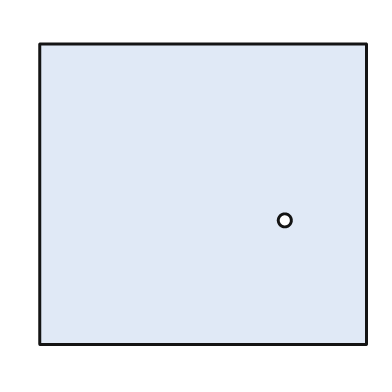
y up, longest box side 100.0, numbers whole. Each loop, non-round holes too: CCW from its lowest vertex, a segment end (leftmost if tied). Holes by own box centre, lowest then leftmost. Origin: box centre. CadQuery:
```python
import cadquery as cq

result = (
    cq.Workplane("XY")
    .moveTo(-50.0, -46.0)
    .lineTo(50.0, -46.0)
    .lineTo(50.0, 46.0)
    .lineTo(-50.0, 46.0)
    .close()
    .moveTo(25.0, -8.0)
    .circle(2.0)
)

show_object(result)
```